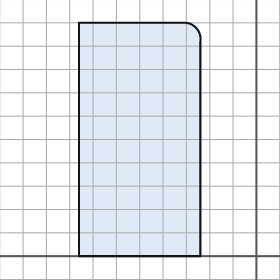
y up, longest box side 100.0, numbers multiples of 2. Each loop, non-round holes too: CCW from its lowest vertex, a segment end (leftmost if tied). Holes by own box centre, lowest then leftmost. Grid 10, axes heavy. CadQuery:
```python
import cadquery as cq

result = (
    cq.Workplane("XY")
    .moveTo(-76.0, 0.0)
    .lineTo(-24.0, 0.0)
    .lineTo(-24.0, 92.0)
    .threePointArc((-26.0, 98.0), (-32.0, 100.0))
    .lineTo(-76.0, 100.0)
    .close()
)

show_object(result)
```